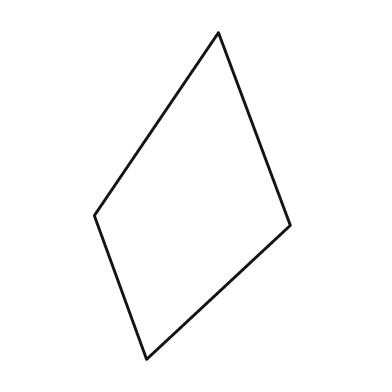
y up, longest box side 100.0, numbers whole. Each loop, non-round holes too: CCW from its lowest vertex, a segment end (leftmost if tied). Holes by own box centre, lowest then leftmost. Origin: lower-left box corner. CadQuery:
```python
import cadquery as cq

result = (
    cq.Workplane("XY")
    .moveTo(16.0, 0.0)
    .lineTo(60.0, 41.0)
    .lineTo(38.0, 100.0)
    .lineTo(0.0, 44.0)
    .close()
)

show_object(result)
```